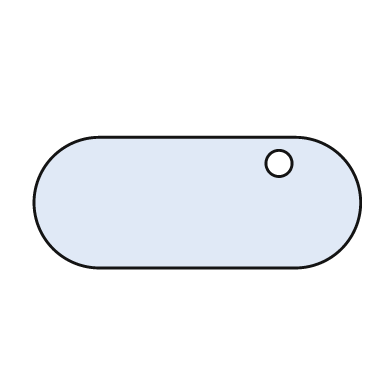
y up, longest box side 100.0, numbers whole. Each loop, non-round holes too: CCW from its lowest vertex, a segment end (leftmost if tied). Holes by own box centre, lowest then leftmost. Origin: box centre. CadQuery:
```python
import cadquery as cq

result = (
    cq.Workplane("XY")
    .moveTo(-30.0, -20.0)
    .lineTo(30.0, -20.0)
    .threePointArc((50.0, 0.0), (30.0, 20.0))
    .lineTo(-30.0, 20.0)
    .threePointArc((-50.0, 0.0), (-30.0, -20.0))
    .close()
    .moveTo(25.0, 12.0)
    .circle(4.0)
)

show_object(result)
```